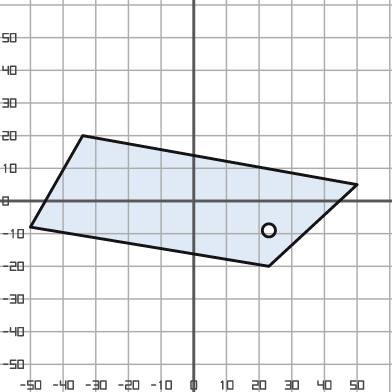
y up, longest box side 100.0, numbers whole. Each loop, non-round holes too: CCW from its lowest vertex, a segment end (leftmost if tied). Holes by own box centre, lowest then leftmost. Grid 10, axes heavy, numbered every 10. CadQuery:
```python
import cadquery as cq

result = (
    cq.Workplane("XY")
    .moveTo(23.0, -20.0)
    .lineTo(50.0, 5.0)
    .lineTo(-34.0, 20.0)
    .lineTo(-50.0, -8.0)
    .close()
    .moveTo(23.0, -9.0)
    .circle(2.0)
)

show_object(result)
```